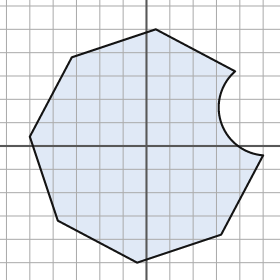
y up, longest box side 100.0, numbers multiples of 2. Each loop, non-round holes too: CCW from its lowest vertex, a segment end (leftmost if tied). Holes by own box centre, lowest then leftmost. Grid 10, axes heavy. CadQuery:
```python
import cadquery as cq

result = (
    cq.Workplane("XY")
    .moveTo(-4.0, -50.0)
    .lineTo(32.0, -38.0)
    .lineTo(50.0, -4.0)
    .threePointArc((32.0, 10.0), (38.0, 32.0))
    .lineTo(4.0, 50.0)
    .lineTo(-32.0, 38.0)
    .lineTo(-50.0, 4.0)
    .lineTo(-38.0, -32.0)
    .close()
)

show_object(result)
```